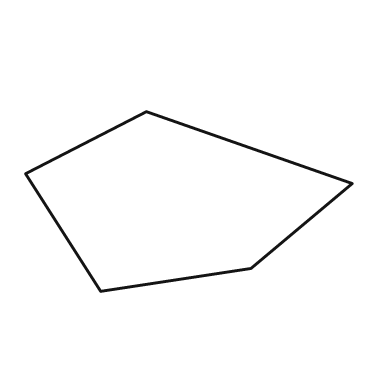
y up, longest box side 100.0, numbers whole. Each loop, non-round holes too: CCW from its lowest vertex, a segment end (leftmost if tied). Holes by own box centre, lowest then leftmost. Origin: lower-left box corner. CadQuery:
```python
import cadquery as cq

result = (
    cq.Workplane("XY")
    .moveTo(23.0, 0.0)
    .lineTo(69.0, 7.0)
    .lineTo(100.0, 33.0)
    .lineTo(37.0, 55.0)
    .lineTo(0.0, 36.0)
    .close()
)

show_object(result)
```